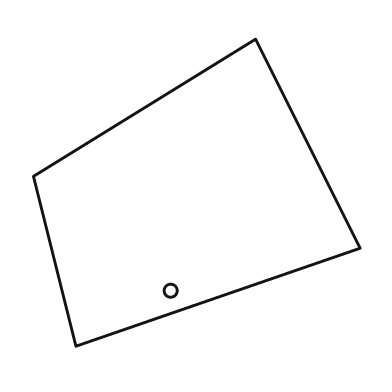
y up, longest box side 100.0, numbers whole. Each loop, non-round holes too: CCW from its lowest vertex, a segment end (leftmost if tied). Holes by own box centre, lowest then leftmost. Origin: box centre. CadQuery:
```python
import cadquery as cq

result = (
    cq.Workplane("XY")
    .moveTo(-37.0, -47.0)
    .lineTo(50.0, -17.0)
    .lineTo(18.0, 47.0)
    .lineTo(-50.0, 5.0)
    .close()
    .moveTo(-8.0, -30.0)
    .circle(2.0)
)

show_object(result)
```